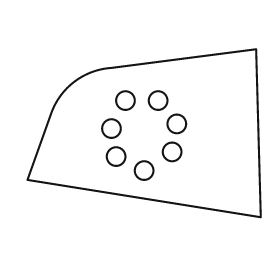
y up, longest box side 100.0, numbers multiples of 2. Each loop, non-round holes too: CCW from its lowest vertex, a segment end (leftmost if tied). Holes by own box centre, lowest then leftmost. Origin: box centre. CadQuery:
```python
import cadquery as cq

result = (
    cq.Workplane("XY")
    .moveTo(50.0, -36.0)
    .lineTo(48.0, 36.0)
    .lineTo(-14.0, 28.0)
    .threePointArc((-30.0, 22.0), (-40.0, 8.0))
    .lineTo(-50.0, -20.0)
    .close()
    .moveTo(0.0, -16.0)
    .circle(4.0)
    .moveTo(-12.0, -10.0)
    .circle(4.0)
    .moveTo(12.0, -8.0)
    .circle(4.0)
    .moveTo(-14.0, 2.0)
    .circle(4.0)
    .moveTo(14.0, 4.0)
    .circle(4.0)
    .moveTo(-8.0, 14.0)
    .circle(4.0)
    .moveTo(6.0, 14.0)
    .circle(4.0)
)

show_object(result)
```